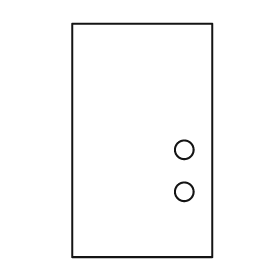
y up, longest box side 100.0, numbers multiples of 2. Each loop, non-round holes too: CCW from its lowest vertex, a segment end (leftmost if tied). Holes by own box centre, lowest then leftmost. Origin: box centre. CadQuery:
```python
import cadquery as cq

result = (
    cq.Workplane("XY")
    .moveTo(-30.0, -50.0)
    .lineTo(30.0, -50.0)
    .lineTo(30.0, 50.0)
    .lineTo(-30.0, 50.0)
    .close()
    .moveTo(18.0, -22.0)
    .circle(4.0)
    .moveTo(18.0, -4.0)
    .circle(4.0)
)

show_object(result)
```